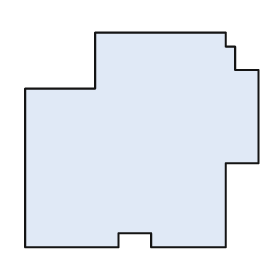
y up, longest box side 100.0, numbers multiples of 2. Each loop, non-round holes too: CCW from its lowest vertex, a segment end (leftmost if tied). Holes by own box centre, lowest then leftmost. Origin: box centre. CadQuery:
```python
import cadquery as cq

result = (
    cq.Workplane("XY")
    .moveTo(-50.0, -46.0)
    .lineTo(-10.0, -46.0)
    .lineTo(-10.0, -40.0)
    .lineTo(4.0, -40.0)
    .lineTo(4.0, -46.0)
    .lineTo(36.0, -46.0)
    .lineTo(36.0, -10.0)
    .lineTo(50.0, -10.0)
    .lineTo(50.0, 30.0)
    .lineTo(40.0, 30.0)
    .lineTo(40.0, 40.0)
    .lineTo(36.0, 40.0)
    .lineTo(36.0, 46.0)
    .lineTo(-20.0, 46.0)
    .lineTo(-20.0, 22.0)
    .lineTo(-50.0, 22.0)
    .close()
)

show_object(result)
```